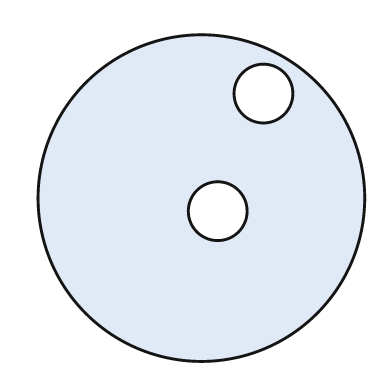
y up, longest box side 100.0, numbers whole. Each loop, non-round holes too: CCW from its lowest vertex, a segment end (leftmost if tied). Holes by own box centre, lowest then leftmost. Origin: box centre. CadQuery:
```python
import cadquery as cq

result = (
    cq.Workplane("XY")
    .moveTo(0.0, 0.0)
    .circle(50.0)
    .moveTo(5.0, -4.0)
    .circle(9.0)
    .moveTo(19.0, 32.0)
    .circle(9.0)
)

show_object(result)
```